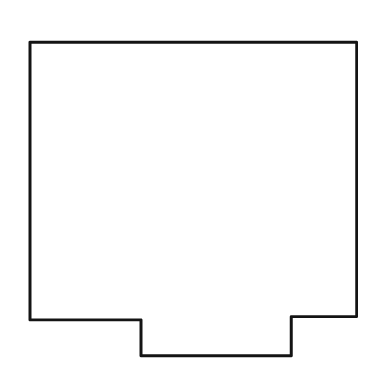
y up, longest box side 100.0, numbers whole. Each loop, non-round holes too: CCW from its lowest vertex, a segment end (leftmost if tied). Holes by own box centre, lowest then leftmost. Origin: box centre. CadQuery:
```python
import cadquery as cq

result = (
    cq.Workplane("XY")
    .moveTo(-16.0, -48.0)
    .lineTo(30.0, -48.0)
    .lineTo(30.0, -36.0)
    .lineTo(50.0, -36.0)
    .lineTo(50.0, 48.0)
    .lineTo(-50.0, 48.0)
    .lineTo(-50.0, -37.0)
    .lineTo(-16.0, -37.0)
    .close()
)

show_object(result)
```